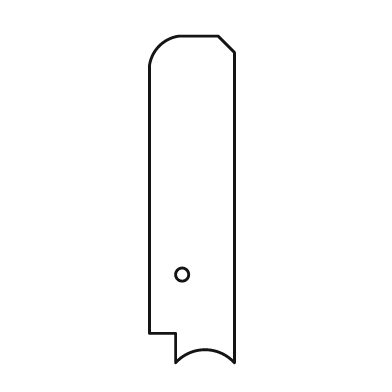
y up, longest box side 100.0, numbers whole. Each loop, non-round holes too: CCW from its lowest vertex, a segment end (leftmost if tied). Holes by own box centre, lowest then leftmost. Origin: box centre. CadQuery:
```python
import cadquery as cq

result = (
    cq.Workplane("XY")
    .moveTo(-5.0, -50.0)
    .threePointArc((4.0, -46.0), (13.0, -50.0))
    .lineTo(13.0, 45.0)
    .lineTo(8.0, 50.0)
    .lineTo(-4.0, 50.0)
    .threePointArc((-10.0, 47.0), (-13.0, 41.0))
    .lineTo(-13.0, -41.0)
    .lineTo(-5.0, -41.0)
    .close()
    .moveTo(-3.0, -23.0)
    .circle(2.0)
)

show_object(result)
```